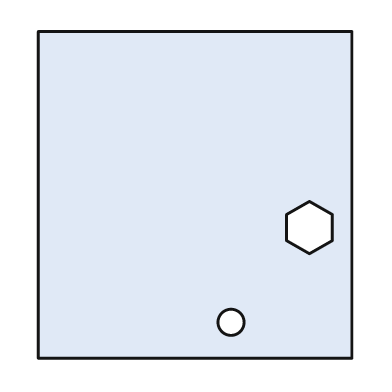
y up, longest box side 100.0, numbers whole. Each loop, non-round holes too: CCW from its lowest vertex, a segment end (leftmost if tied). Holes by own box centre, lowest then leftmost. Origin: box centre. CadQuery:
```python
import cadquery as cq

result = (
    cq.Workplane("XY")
    .moveTo(-48.0, -50.0)
    .lineTo(48.0, -50.0)
    .lineTo(48.0, 50.0)
    .lineTo(-48.0, 50.0)
    .close()
    .moveTo(11.0, -39.0)
    .circle(4.0)
    .moveTo(35.0, -18.0)
    .lineTo(42.0, -14.0)
    .lineTo(42.0, -6.0)
    .lineTo(35.0, -2.0)
    .lineTo(28.0, -6.0)
    .lineTo(28.0, -14.0)
    .close()
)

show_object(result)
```